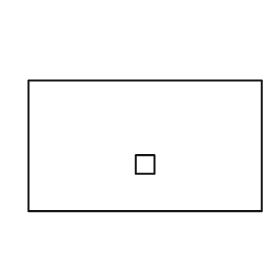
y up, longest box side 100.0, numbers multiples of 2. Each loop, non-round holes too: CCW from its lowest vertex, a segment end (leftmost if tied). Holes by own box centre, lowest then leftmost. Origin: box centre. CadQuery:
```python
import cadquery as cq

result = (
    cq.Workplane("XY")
    .moveTo(-50.0, -28.0)
    .lineTo(50.0, -28.0)
    .lineTo(50.0, 28.0)
    .lineTo(-50.0, 28.0)
    .close()
    .moveTo(-4.0, -12.0)
    .lineTo(4.0, -12.0)
    .lineTo(4.0, -4.0)
    .lineTo(-4.0, -4.0)
    .close()
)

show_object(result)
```